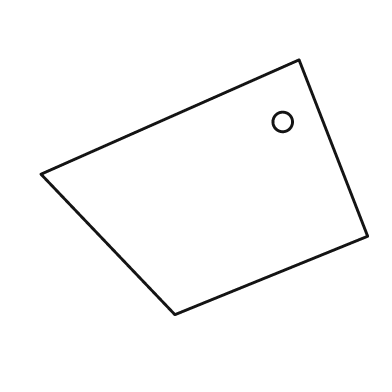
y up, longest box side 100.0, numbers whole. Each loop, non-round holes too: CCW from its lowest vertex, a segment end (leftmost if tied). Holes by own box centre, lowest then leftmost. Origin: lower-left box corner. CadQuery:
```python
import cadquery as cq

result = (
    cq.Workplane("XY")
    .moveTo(41.0, 0.0)
    .lineTo(100.0, 24.0)
    .lineTo(79.0, 78.0)
    .lineTo(0.0, 43.0)
    .close()
    .moveTo(74.0, 59.0)
    .circle(3.0)
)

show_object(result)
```